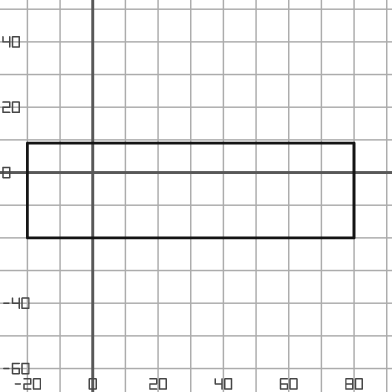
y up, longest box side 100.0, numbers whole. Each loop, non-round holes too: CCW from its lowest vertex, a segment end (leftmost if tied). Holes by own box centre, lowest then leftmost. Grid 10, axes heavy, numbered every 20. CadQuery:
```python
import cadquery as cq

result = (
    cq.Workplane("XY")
    .moveTo(-20.0, -20.0)
    .lineTo(80.0, -20.0)
    .lineTo(80.0, 9.0)
    .lineTo(-20.0, 9.0)
    .close()
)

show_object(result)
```